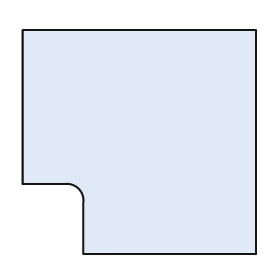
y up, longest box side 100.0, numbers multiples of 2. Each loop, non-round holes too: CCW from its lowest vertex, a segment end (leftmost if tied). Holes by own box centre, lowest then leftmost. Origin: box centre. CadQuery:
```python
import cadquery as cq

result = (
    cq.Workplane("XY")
    .moveTo(-24.0, -48.0)
    .lineTo(50.0, -48.0)
    .lineTo(50.0, 48.0)
    .lineTo(-50.0, 48.0)
    .lineTo(-50.0, -18.0)
    .lineTo(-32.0, -18.0)
    .threePointArc((-26.0, -20.0), (-24.0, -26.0))
    .close()
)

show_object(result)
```